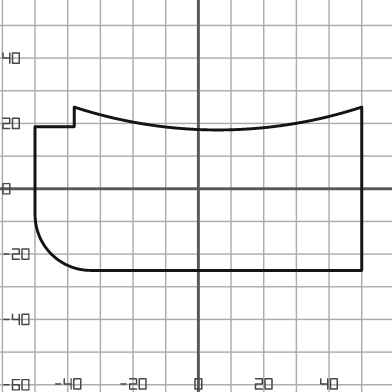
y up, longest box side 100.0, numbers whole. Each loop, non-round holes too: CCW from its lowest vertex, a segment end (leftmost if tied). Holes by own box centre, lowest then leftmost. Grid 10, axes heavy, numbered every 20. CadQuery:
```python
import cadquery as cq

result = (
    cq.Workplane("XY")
    .moveTo(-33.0, -25.0)
    .lineTo(50.0, -25.0)
    .lineTo(50.0, 25.0)
    .threePointArc((6.0, 18.0), (-38.0, 25.0))
    .lineTo(-38.0, 19.0)
    .lineTo(-50.0, 19.0)
    .lineTo(-50.0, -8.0)
    .threePointArc((-45.0, -20.0), (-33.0, -25.0))
    .close()
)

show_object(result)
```